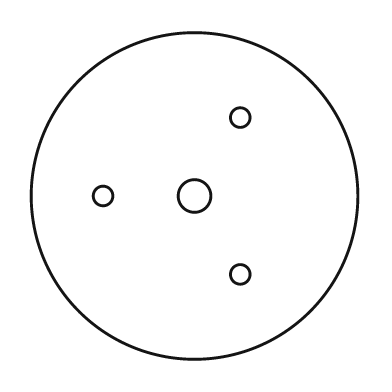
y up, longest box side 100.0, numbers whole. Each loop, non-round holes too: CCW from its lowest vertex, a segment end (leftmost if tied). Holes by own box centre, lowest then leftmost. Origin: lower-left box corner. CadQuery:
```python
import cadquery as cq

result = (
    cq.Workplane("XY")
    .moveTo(50.0, 50.0)
    .circle(50.0)
    .moveTo(64.0, 26.0)
    .circle(3.0)
    .moveTo(22.0, 50.0)
    .circle(3.0)
    .moveTo(50.0, 50.0)
    .circle(5.0)
    .moveTo(64.0, 74.0)
    .circle(3.0)
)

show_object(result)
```